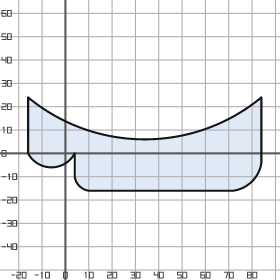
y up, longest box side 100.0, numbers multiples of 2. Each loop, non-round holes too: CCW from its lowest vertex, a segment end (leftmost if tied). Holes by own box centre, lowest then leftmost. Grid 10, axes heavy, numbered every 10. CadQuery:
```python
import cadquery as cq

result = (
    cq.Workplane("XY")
    .moveTo(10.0, -16.0)
    .lineTo(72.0, -16.0)
    .threePointArc((80.0, -12.0), (84.0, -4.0))
    .lineTo(84.0, 24.0)
    .threePointArc((34.0, 6.0), (-16.0, 24.0))
    .lineTo(-16.0, 0.0)
    .threePointArc((-6.0, -6.0), (4.0, 0.0))
    .lineTo(4.0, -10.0)
    .threePointArc((6.0, -14.0), (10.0, -16.0))
    .close()
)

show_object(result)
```